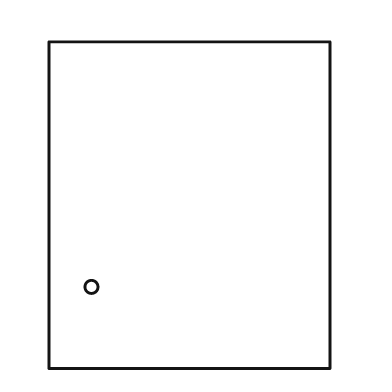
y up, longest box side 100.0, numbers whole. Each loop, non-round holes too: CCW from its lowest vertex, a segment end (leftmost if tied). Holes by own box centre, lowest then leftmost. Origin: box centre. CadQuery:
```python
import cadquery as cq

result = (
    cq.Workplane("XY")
    .moveTo(-43.0, -50.0)
    .lineTo(43.0, -50.0)
    .lineTo(43.0, 50.0)
    .lineTo(-43.0, 50.0)
    .close()
    .moveTo(-30.0, -25.0)
    .circle(2.0)
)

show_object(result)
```